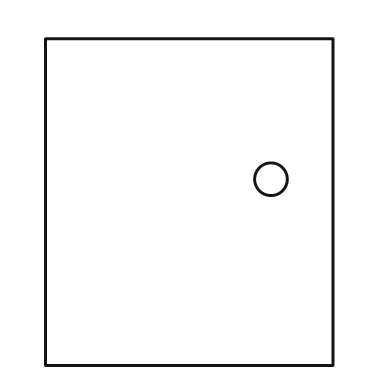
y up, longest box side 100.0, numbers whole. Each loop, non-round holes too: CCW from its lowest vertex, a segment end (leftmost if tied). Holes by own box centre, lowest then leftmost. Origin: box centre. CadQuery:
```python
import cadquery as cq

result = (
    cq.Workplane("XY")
    .moveTo(-44.0, -50.0)
    .lineTo(44.0, -50.0)
    .lineTo(44.0, 50.0)
    .lineTo(-44.0, 50.0)
    .close()
    .moveTo(25.0, 7.0)
    .circle(5.0)
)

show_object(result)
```